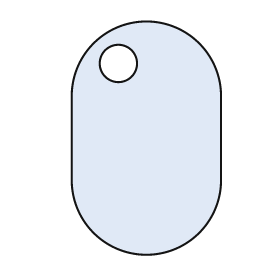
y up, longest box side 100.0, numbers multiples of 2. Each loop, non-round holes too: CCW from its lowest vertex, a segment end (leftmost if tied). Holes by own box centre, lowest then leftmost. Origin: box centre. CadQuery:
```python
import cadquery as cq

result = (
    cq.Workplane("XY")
    .moveTo(-32.0, -18.0)
    .threePointArc((0.0, -50.0), (32.0, -18.0))
    .lineTo(32.0, 18.0)
    .threePointArc((0.0, 50.0), (-32.0, 18.0))
    .close()
    .moveTo(-12.0, 32.0)
    .circle(8.0)
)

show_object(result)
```